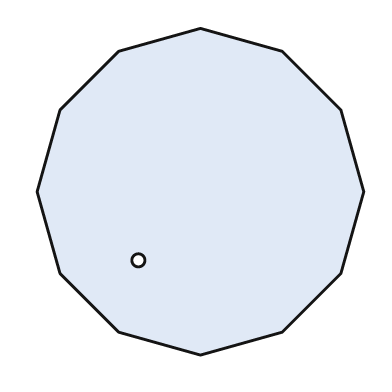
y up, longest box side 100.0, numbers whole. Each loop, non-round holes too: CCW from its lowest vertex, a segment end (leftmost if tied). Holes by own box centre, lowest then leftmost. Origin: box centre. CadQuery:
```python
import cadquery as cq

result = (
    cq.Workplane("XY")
    .moveTo(0.0, -50.0)
    .lineTo(25.0, -43.0)
    .lineTo(43.0, -25.0)
    .lineTo(50.0, 0.0)
    .lineTo(43.0, 25.0)
    .lineTo(25.0, 43.0)
    .lineTo(0.0, 50.0)
    .lineTo(-25.0, 43.0)
    .lineTo(-43.0, 25.0)
    .lineTo(-50.0, 0.0)
    .lineTo(-43.0, -25.0)
    .lineTo(-25.0, -43.0)
    .close()
    .moveTo(-19.0, -21.0)
    .circle(2.0)
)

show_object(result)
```